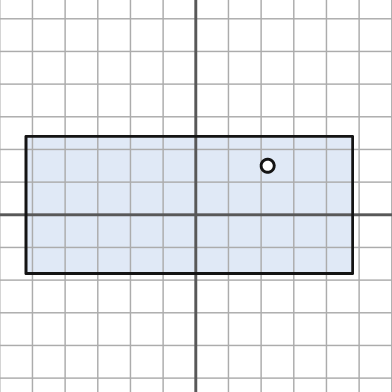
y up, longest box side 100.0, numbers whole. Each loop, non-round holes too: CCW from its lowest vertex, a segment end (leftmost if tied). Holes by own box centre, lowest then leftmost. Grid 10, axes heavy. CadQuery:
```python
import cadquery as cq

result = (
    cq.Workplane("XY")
    .moveTo(-52.0, -18.0)
    .lineTo(48.0, -18.0)
    .lineTo(48.0, 24.0)
    .lineTo(-52.0, 24.0)
    .close()
    .moveTo(22.0, 15.0)
    .circle(2.0)
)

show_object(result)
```